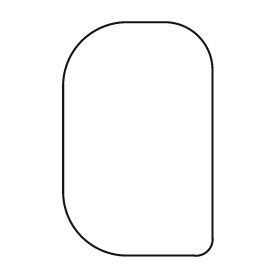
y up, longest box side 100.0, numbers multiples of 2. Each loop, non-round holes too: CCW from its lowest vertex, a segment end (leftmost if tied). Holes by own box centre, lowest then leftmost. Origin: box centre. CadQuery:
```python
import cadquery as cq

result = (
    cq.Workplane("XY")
    .moveTo(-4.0, -50.0)
    .lineTo(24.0, -50.0)
    .threePointArc((30.0, -48.0), (32.0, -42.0))
    .lineTo(32.0, 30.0)
    .threePointArc((26.0, 44.0), (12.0, 50.0))
    .lineTo(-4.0, 50.0)
    .threePointArc((-24.0, 42.0), (-32.0, 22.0))
    .lineTo(-32.0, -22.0)
    .threePointArc((-24.0, -42.0), (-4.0, -50.0))
    .close()
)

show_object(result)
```